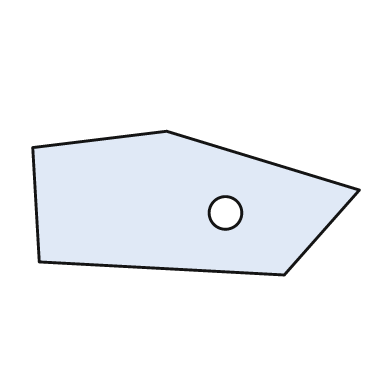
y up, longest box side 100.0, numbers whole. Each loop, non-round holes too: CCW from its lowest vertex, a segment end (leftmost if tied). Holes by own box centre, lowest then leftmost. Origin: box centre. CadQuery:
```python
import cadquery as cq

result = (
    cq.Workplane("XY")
    .moveTo(27.0, -22.0)
    .lineTo(50.0, 4.0)
    .lineTo(-9.0, 22.0)
    .lineTo(-50.0, 17.0)
    .lineTo(-48.0, -18.0)
    .close()
    .moveTo(9.0, -3.0)
    .circle(5.0)
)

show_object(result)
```